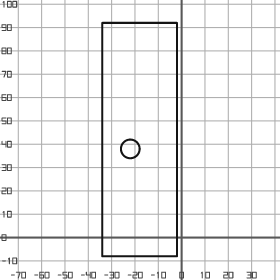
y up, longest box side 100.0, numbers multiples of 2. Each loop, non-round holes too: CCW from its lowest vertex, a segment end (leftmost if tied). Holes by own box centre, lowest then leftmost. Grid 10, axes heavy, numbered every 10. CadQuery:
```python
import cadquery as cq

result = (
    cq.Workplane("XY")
    .moveTo(-34.0, -8.0)
    .lineTo(-2.0, -8.0)
    .lineTo(-2.0, 92.0)
    .lineTo(-34.0, 92.0)
    .close()
    .moveTo(-22.0, 38.0)
    .circle(4.0)
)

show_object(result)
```